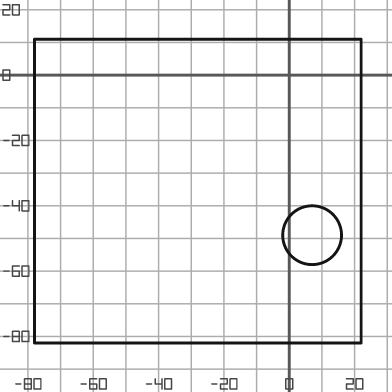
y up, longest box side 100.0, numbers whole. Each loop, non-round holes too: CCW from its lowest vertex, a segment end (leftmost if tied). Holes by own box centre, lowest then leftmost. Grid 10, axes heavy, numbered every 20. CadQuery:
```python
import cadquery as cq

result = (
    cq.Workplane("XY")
    .moveTo(-78.0, -82.0)
    .lineTo(22.0, -82.0)
    .lineTo(22.0, 11.0)
    .lineTo(-78.0, 11.0)
    .close()
    .moveTo(7.0, -49.0)
    .circle(9.0)
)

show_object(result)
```